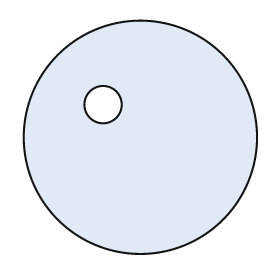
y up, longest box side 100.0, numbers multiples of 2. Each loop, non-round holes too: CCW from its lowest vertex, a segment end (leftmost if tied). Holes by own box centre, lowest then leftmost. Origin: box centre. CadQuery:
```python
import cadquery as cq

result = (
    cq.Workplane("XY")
    .moveTo(0.0, 0.0)
    .circle(50.0)
    .moveTo(-16.0, 14.0)
    .circle(8.0)
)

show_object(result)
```